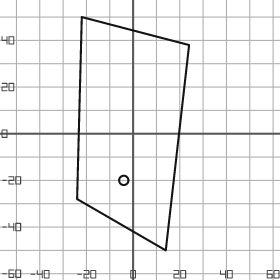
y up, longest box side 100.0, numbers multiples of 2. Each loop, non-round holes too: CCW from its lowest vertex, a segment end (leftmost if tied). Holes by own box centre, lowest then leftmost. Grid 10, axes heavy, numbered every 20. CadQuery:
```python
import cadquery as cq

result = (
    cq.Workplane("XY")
    .moveTo(14.0, -50.0)
    .lineTo(24.0, 38.0)
    .lineTo(-22.0, 50.0)
    .lineTo(-24.0, -28.0)
    .close()
    .moveTo(-4.0, -20.0)
    .circle(2.0)
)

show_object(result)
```